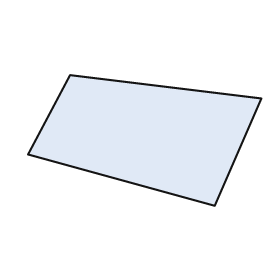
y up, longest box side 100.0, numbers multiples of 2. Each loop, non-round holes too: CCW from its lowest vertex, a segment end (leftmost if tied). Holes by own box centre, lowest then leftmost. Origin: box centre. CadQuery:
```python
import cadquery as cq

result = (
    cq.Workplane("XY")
    .moveTo(30.0, -28.0)
    .lineTo(50.0, 18.0)
    .lineTo(-32.0, 28.0)
    .lineTo(-50.0, -6.0)
    .close()
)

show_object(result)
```